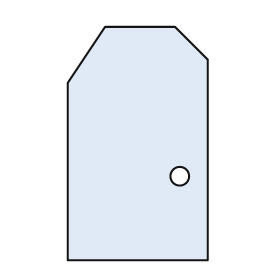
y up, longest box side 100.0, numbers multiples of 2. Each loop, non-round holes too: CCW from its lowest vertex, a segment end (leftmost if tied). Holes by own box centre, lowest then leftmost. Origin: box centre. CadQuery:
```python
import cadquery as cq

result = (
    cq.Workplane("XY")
    .moveTo(-30.0, -50.0)
    .lineTo(30.0, -50.0)
    .lineTo(30.0, 36.0)
    .lineTo(16.0, 50.0)
    .lineTo(-14.0, 50.0)
    .lineTo(-30.0, 26.0)
    .close()
    .moveTo(18.0, -14.0)
    .circle(4.0)
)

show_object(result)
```